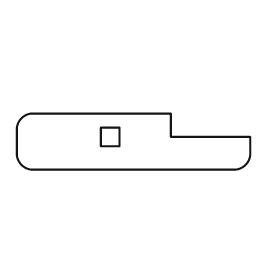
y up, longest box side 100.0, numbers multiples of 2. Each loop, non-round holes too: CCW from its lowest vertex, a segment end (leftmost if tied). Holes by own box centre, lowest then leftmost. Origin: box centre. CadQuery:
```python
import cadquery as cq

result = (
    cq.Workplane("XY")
    .moveTo(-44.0, -12.0)
    .lineTo(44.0, -12.0)
    .threePointArc((48.0, -10.0), (50.0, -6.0))
    .lineTo(50.0, 2.0)
    .lineTo(16.0, 2.0)
    .lineTo(16.0, 12.0)
    .lineTo(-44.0, 12.0)
    .threePointArc((-48.0, 10.0), (-50.0, 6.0))
    .lineTo(-50.0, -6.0)
    .threePointArc((-48.0, -10.0), (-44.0, -12.0))
    .close()
    .moveTo(-14.0, -2.0)
    .lineTo(-6.0, -2.0)
    .lineTo(-6.0, 6.0)
    .lineTo(-14.0, 6.0)
    .close()
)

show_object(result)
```